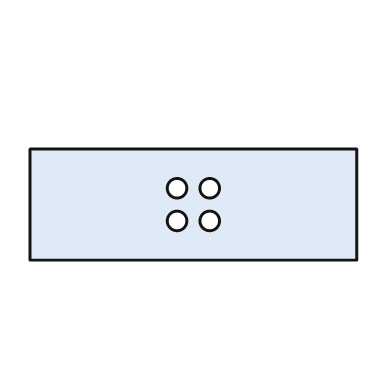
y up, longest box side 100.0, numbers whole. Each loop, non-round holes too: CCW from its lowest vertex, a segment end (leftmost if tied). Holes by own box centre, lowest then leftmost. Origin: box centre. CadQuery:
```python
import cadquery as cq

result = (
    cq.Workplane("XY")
    .moveTo(-50.0, -17.0)
    .lineTo(50.0, -17.0)
    .lineTo(50.0, 17.0)
    .lineTo(-50.0, 17.0)
    .close()
    .moveTo(-5.0, -5.0)
    .circle(3.0)
    .moveTo(5.0, -5.0)
    .circle(3.0)
    .moveTo(-5.0, 5.0)
    .circle(3.0)
    .moveTo(5.0, 5.0)
    .circle(3.0)
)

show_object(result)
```